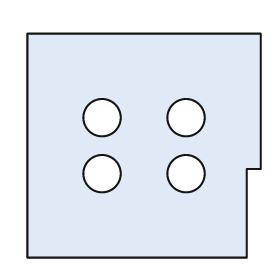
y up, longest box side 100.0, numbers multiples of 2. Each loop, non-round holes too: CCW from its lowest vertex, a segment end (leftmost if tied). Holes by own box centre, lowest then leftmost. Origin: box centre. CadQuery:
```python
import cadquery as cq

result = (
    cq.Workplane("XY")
    .moveTo(-50.0, -48.0)
    .lineTo(44.0, -48.0)
    .lineTo(44.0, -10.0)
    .lineTo(50.0, -10.0)
    .lineTo(50.0, 48.0)
    .lineTo(-50.0, 48.0)
    .close()
    .moveTo(-18.0, -12.0)
    .circle(8.0)
    .moveTo(18.0, -12.0)
    .circle(8.0)
    .moveTo(-18.0, 12.0)
    .circle(8.0)
    .moveTo(18.0, 12.0)
    .circle(8.0)
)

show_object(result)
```